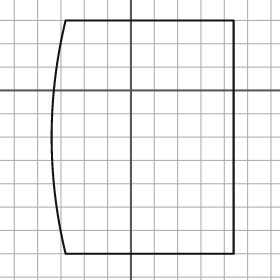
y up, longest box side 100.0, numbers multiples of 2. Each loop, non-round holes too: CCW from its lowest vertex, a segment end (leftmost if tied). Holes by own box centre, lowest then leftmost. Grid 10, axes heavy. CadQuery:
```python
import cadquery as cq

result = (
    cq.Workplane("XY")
    .moveTo(-28.0, -70.0)
    .lineTo(44.0, -70.0)
    .lineTo(44.0, 30.0)
    .lineTo(-28.0, 30.0)
    .threePointArc((-34.0, -20.0), (-28.0, -70.0))
    .close()
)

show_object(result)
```